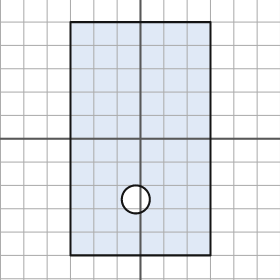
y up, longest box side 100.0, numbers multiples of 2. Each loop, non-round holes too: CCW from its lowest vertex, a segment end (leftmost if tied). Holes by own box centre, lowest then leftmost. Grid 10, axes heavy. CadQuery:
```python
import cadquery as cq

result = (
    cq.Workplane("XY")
    .moveTo(-30.0, -50.0)
    .lineTo(30.0, -50.0)
    .lineTo(30.0, 50.0)
    .lineTo(-30.0, 50.0)
    .close()
    .moveTo(-2.0, -26.0)
    .circle(6.0)
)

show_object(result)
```